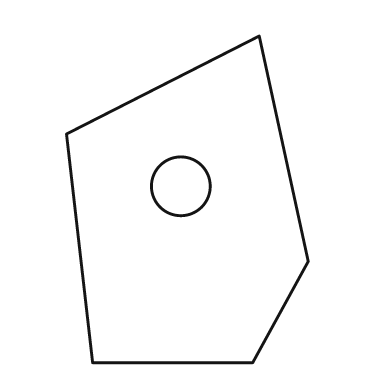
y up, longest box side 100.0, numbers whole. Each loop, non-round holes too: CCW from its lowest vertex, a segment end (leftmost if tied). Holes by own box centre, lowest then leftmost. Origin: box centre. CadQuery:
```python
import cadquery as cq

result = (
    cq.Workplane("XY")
    .moveTo(-29.0, -50.0)
    .lineTo(20.0, -50.0)
    .lineTo(37.0, -19.0)
    .lineTo(22.0, 50.0)
    .lineTo(-37.0, 20.0)
    .close()
    .moveTo(-2.0, 4.0)
    .circle(9.0)
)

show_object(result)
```